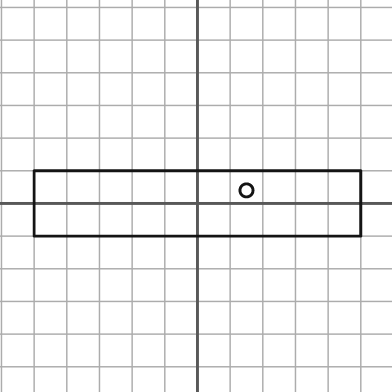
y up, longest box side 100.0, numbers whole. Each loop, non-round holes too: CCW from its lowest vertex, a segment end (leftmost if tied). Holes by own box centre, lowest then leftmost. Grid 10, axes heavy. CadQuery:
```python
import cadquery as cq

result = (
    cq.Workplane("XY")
    .moveTo(-50.0, -10.0)
    .lineTo(50.0, -10.0)
    .lineTo(50.0, 10.0)
    .lineTo(-50.0, 10.0)
    .close()
    .moveTo(15.0, 4.0)
    .circle(2.0)
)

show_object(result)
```